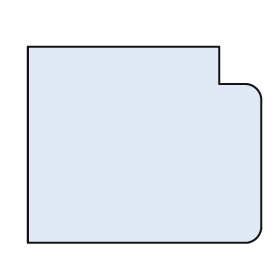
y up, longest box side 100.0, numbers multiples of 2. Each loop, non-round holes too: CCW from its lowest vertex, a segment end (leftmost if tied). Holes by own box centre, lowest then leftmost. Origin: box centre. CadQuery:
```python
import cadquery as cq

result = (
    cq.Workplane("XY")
    .moveTo(-50.0, -42.0)
    .lineTo(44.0, -42.0)
    .threePointArc((48.0, -40.0), (50.0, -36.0))
    .lineTo(50.0, 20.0)
    .threePointArc((48.0, 24.0), (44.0, 26.0))
    .lineTo(32.0, 26.0)
    .lineTo(32.0, 42.0)
    .lineTo(-50.0, 42.0)
    .close()
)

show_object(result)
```